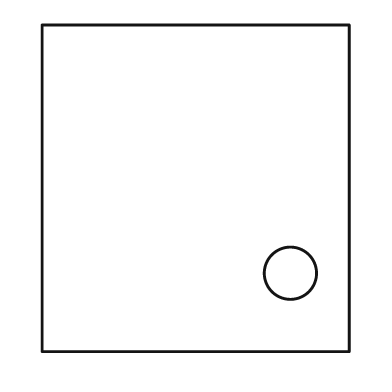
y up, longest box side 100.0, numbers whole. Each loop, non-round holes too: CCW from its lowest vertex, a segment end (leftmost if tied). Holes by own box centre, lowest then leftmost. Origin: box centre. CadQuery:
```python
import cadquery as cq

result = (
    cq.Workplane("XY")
    .moveTo(-47.0, -50.0)
    .lineTo(47.0, -50.0)
    .lineTo(47.0, 50.0)
    .lineTo(-47.0, 50.0)
    .close()
    .moveTo(29.0, -26.0)
    .circle(8.0)
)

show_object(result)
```